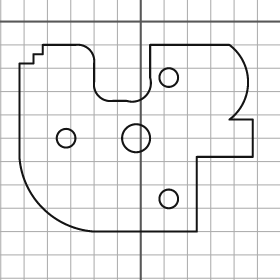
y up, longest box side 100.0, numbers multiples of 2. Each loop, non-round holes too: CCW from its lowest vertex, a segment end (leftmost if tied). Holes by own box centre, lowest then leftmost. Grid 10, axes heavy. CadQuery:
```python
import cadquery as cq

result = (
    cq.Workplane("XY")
    .moveTo(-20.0, -90.0)
    .lineTo(24.0, -90.0)
    .lineTo(24.0, -58.0)
    .lineTo(48.0, -58.0)
    .lineTo(48.0, -42.0)
    .lineTo(38.0, -42.0)
    .threePointArc((46.0, -26.0), (38.0, -10.0))
    .lineTo(4.0, -10.0)
    .lineTo(4.0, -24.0)
    .threePointArc((2.0, -32.0), (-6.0, -34.0))
    .lineTo(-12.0, -34.0)
    .threePointArc((-18.0, -32.0), (-20.0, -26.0))
    .lineTo(-20.0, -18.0)
    .threePointArc((-22.0, -12.0), (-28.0, -10.0))
    .lineTo(-42.0, -10.0)
    .lineTo(-42.0, -14.0)
    .lineTo(-46.0, -14.0)
    .lineTo(-46.0, -18.0)
    .lineTo(-52.0, -18.0)
    .lineTo(-52.0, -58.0)
    .threePointArc((-42.0, -80.0), (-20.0, -90.0))
    .close()
    .moveTo(12.0, -76.0)
    .circle(4.0)
    .moveTo(-32.0, -50.0)
    .circle(4.0)
    .moveTo(-2.0, -50.0)
    .circle(6.0)
    .moveTo(12.0, -24.0)
    .circle(4.0)
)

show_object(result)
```